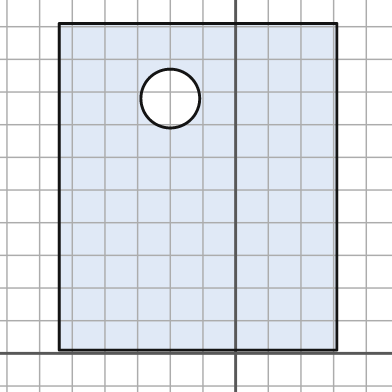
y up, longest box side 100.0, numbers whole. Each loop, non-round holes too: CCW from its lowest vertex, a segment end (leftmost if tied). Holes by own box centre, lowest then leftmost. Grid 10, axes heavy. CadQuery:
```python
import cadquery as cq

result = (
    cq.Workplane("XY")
    .moveTo(-54.0, 1.0)
    .lineTo(31.0, 1.0)
    .lineTo(31.0, 101.0)
    .lineTo(-54.0, 101.0)
    .close()
    .moveTo(-20.0, 78.0)
    .circle(9.0)
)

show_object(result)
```